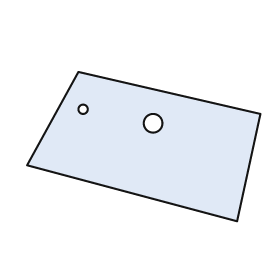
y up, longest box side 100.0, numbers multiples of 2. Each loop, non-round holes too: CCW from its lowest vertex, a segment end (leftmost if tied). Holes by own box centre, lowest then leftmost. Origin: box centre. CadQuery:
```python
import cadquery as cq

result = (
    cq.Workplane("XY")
    .moveTo(40.0, -32.0)
    .lineTo(50.0, 14.0)
    .lineTo(-28.0, 32.0)
    .lineTo(-50.0, -8.0)
    .close()
    .moveTo(4.0, 10.0)
    .circle(4.0)
    .moveTo(-26.0, 16.0)
    .circle(2.0)
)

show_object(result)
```